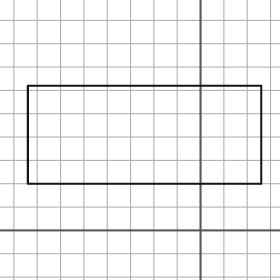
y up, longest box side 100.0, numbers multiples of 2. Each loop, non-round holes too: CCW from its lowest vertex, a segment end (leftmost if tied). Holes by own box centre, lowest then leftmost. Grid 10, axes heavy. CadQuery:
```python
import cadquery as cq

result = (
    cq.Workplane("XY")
    .moveTo(-74.0, 20.0)
    .lineTo(26.0, 20.0)
    .lineTo(26.0, 62.0)
    .lineTo(-74.0, 62.0)
    .close()
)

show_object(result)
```